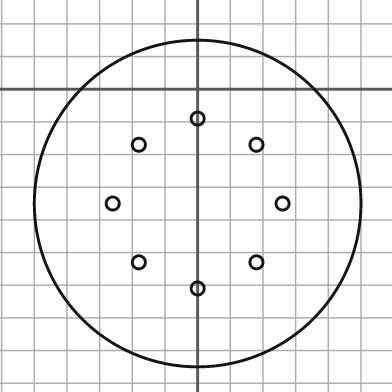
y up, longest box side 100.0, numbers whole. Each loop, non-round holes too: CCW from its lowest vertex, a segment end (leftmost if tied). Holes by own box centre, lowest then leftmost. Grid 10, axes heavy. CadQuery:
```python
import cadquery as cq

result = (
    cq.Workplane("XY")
    .moveTo(0.0, -35.0)
    .circle(50.0)
    .moveTo(0.0, -61.0)
    .circle(2.0)
    .moveTo(-18.0, -53.0)
    .circle(2.0)
    .moveTo(18.0, -53.0)
    .circle(2.0)
    .moveTo(-26.0, -35.0)
    .circle(2.0)
    .moveTo(26.0, -35.0)
    .circle(2.0)
    .moveTo(-18.0, -17.0)
    .circle(2.0)
    .moveTo(18.0, -17.0)
    .circle(2.0)
    .moveTo(0.0, -9.0)
    .circle(2.0)
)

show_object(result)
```